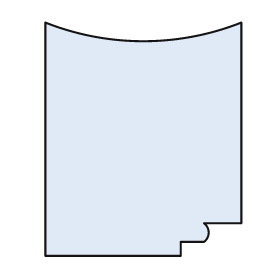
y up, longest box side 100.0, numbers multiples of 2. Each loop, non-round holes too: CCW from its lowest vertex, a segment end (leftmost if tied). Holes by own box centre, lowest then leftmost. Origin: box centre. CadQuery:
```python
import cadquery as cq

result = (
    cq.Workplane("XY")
    .moveTo(-42.0, -50.0)
    .lineTo(16.0, -50.0)
    .lineTo(16.0, -44.0)
    .lineTo(26.0, -44.0)
    .threePointArc((28.0, -40.0), (26.0, -36.0))
    .lineTo(42.0, -36.0)
    .lineTo(42.0, 50.0)
    .threePointArc((0.0, 42.0), (-42.0, 50.0))
    .close()
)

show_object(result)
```